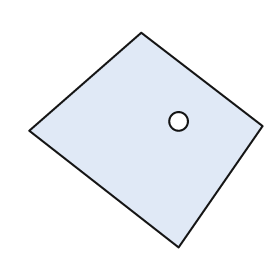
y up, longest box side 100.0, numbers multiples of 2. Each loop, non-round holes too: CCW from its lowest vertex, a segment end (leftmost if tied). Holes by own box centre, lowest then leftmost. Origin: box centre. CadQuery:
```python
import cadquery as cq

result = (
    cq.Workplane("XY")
    .moveTo(14.0, -46.0)
    .lineTo(50.0, 6.0)
    .lineTo(-2.0, 46.0)
    .lineTo(-50.0, 4.0)
    .close()
    .moveTo(14.0, 8.0)
    .circle(4.0)
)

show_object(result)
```